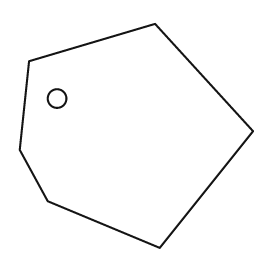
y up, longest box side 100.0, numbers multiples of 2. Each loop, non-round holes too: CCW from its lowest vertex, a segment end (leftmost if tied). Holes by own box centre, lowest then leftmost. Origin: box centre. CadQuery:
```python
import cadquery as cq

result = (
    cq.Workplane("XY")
    .moveTo(10.0, -48.0)
    .lineTo(50.0, 2.0)
    .lineTo(8.0, 48.0)
    .lineTo(-46.0, 32.0)
    .lineTo(-50.0, -6.0)
    .lineTo(-38.0, -28.0)
    .close()
    .moveTo(-34.0, 16.0)
    .circle(4.0)
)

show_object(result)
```